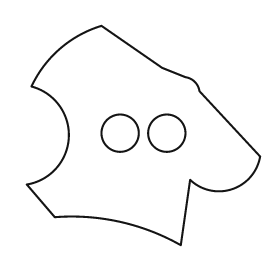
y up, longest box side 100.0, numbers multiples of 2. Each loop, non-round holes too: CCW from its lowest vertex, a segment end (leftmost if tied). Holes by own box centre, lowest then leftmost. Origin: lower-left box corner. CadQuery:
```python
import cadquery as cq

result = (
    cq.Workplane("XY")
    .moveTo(66.0, 0.0)
    .lineTo(70.0, 28.0)
    .threePointArc((88.0, 24.0), (100.0, 38.0))
    .lineTo(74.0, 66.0)
    .threePointArc((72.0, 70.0), (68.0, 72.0))
    .lineTo(58.0, 76.0)
    .lineTo(32.0, 94.0)
    .threePointArc((14.0, 84.0), (2.0, 68.0))
    .threePointArc((18.0, 46.0), (0.0, 26.0))
    .lineTo(12.0, 12.0)
    .threePointArc((40.0, 10.0), (66.0, 0.0))
    .close()
    .moveTo(40.0, 48.0)
    .circle(8.0)
    .moveTo(60.0, 48.0)
    .circle(8.0)
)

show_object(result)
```